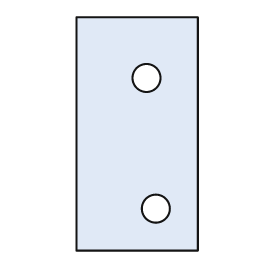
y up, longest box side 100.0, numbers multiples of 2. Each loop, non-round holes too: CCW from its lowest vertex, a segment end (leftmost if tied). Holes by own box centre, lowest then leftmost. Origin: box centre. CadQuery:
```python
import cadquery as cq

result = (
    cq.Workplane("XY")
    .moveTo(-26.0, -50.0)
    .lineTo(26.0, -50.0)
    .lineTo(26.0, 50.0)
    .lineTo(-26.0, 50.0)
    .close()
    .moveTo(8.0, -32.0)
    .circle(6.0)
    .moveTo(4.0, 24.0)
    .circle(6.0)
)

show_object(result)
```